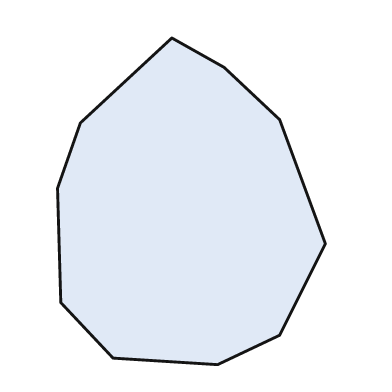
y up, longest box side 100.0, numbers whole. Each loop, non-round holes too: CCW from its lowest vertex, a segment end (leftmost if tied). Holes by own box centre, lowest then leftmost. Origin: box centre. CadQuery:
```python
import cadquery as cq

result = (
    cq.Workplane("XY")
    .moveTo(8.0, -50.0)
    .lineTo(27.0, -41.0)
    .lineTo(41.0, -13.0)
    .lineTo(27.0, 25.0)
    .lineTo(10.0, 41.0)
    .lineTo(-6.0, 50.0)
    .lineTo(-34.0, 24.0)
    .lineTo(-41.0, 4.0)
    .lineTo(-40.0, -31.0)
    .lineTo(-24.0, -48.0)
    .close()
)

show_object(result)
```